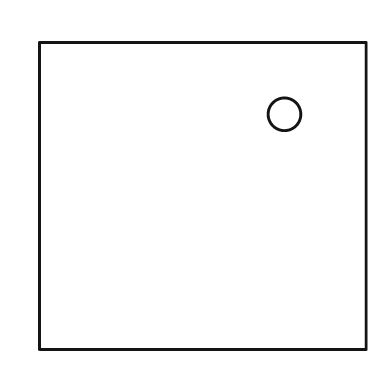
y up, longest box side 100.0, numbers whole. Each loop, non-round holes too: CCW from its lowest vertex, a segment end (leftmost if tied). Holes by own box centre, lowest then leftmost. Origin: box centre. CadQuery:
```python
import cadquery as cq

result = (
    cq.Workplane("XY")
    .moveTo(-50.0, -47.0)
    .lineTo(50.0, -47.0)
    .lineTo(50.0, 47.0)
    .lineTo(-50.0, 47.0)
    .close()
    .moveTo(25.0, 25.0)
    .circle(5.0)
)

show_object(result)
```